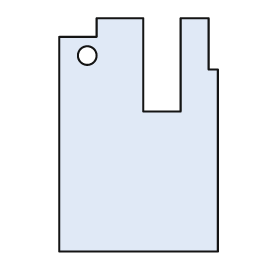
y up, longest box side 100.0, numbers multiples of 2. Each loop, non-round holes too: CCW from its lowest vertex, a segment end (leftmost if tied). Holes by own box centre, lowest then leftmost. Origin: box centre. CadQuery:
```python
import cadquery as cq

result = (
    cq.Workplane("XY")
    .moveTo(-34.0, -50.0)
    .lineTo(34.0, -50.0)
    .lineTo(34.0, 28.0)
    .lineTo(30.0, 28.0)
    .lineTo(30.0, 50.0)
    .lineTo(18.0, 50.0)
    .lineTo(18.0, 10.0)
    .lineTo(2.0, 10.0)
    .lineTo(2.0, 50.0)
    .lineTo(-18.0, 50.0)
    .lineTo(-18.0, 42.0)
    .lineTo(-34.0, 42.0)
    .close()
    .moveTo(-22.0, 34.0)
    .circle(4.0)
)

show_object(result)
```